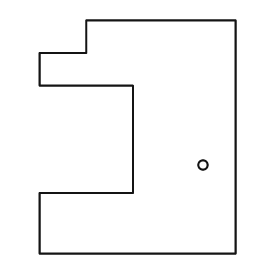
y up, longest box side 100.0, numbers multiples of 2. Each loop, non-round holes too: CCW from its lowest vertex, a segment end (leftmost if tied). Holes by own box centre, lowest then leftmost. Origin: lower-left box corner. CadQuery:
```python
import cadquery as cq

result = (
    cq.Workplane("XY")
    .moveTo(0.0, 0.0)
    .lineTo(84.0, 0.0)
    .lineTo(84.0, 100.0)
    .lineTo(20.0, 100.0)
    .lineTo(20.0, 86.0)
    .lineTo(0.0, 86.0)
    .lineTo(0.0, 72.0)
    .lineTo(40.0, 72.0)
    .lineTo(40.0, 26.0)
    .lineTo(0.0, 26.0)
    .close()
    .moveTo(70.0, 38.0)
    .circle(2.0)
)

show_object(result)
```